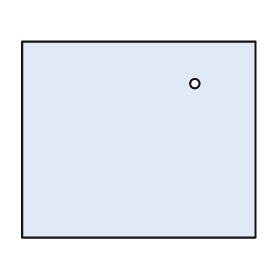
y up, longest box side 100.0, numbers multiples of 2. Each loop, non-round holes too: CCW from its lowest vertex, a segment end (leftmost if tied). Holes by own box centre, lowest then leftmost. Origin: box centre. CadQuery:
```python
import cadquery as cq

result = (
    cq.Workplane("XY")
    .moveTo(-50.0, -42.0)
    .lineTo(50.0, -42.0)
    .lineTo(50.0, 42.0)
    .lineTo(-50.0, 42.0)
    .close()
    .moveTo(24.0, 24.0)
    .circle(2.0)
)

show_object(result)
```